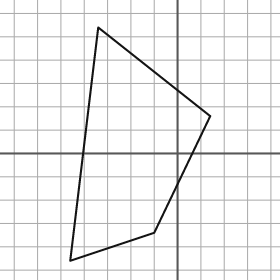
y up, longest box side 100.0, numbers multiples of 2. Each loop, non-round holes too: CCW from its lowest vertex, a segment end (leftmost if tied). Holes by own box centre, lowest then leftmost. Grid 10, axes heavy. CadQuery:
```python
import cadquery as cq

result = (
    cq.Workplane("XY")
    .moveTo(-46.0, -46.0)
    .lineTo(-10.0, -34.0)
    .lineTo(14.0, 16.0)
    .lineTo(-34.0, 54.0)
    .close()
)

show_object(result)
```